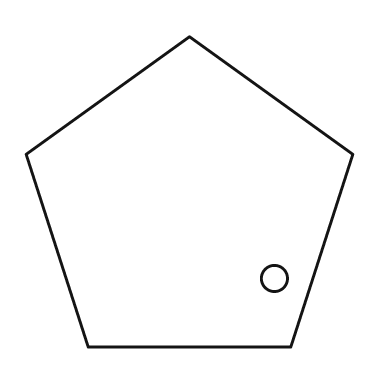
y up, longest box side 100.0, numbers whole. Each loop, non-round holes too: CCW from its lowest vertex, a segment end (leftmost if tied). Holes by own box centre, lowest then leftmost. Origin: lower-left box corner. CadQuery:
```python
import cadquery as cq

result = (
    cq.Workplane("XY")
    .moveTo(19.0, 0.0)
    .lineTo(81.0, 0.0)
    .lineTo(100.0, 59.0)
    .lineTo(50.0, 95.0)
    .lineTo(0.0, 59.0)
    .close()
    .moveTo(76.0, 21.0)
    .circle(4.0)
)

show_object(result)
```